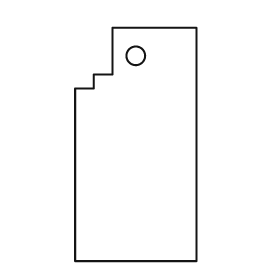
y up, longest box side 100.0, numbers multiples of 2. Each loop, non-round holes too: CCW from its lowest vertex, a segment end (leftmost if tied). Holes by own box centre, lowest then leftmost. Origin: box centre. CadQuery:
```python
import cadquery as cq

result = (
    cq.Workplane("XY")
    .moveTo(-26.0, -50.0)
    .lineTo(26.0, -50.0)
    .lineTo(26.0, 50.0)
    .lineTo(-10.0, 50.0)
    .lineTo(-10.0, 30.0)
    .lineTo(-18.0, 30.0)
    .lineTo(-18.0, 24.0)
    .lineTo(-26.0, 24.0)
    .close()
    .moveTo(0.0, 38.0)
    .circle(4.0)
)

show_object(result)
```